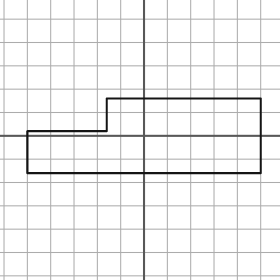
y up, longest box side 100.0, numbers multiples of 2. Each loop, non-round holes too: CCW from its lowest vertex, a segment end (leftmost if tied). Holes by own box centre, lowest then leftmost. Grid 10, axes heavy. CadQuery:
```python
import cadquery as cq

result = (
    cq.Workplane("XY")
    .moveTo(-50.0, -16.0)
    .lineTo(50.0, -16.0)
    .lineTo(50.0, 16.0)
    .lineTo(-16.0, 16.0)
    .lineTo(-16.0, 2.0)
    .lineTo(-50.0, 2.0)
    .close()
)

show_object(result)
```